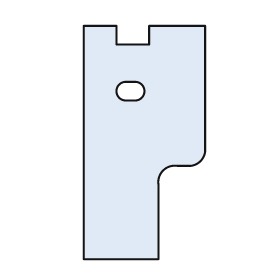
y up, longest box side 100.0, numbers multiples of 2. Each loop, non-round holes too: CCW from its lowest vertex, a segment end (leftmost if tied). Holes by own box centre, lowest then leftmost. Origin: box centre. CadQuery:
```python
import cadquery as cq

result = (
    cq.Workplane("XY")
    .moveTo(-26.0, -50.0)
    .lineTo(6.0, -50.0)
    .lineTo(6.0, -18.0)
    .threePointArc((8.0, -12.0), (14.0, -10.0))
    .lineTo(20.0, -10.0)
    .threePointArc((24.0, -8.0), (26.0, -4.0))
    .lineTo(26.0, 50.0)
    .lineTo(2.0, 50.0)
    .lineTo(2.0, 42.0)
    .lineTo(-12.0, 42.0)
    .lineTo(-12.0, 50.0)
    .lineTo(-26.0, 50.0)
    .close()
    .moveTo(-8.0, 18.0)
    .lineTo(-4.0, 18.0)
    .threePointArc((0.0, 22.0), (-4.0, 26.0))
    .lineTo(-8.0, 26.0)
    .threePointArc((-12.0, 22.0), (-8.0, 18.0))
    .close()
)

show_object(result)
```